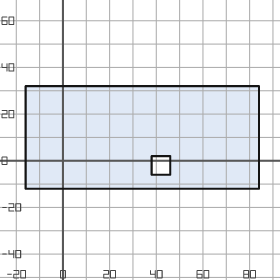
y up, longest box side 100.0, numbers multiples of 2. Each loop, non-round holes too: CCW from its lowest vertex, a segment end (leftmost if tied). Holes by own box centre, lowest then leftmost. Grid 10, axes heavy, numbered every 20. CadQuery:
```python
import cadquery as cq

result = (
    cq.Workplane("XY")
    .moveTo(-16.0, -12.0)
    .lineTo(84.0, -12.0)
    .lineTo(84.0, 32.0)
    .lineTo(-16.0, 32.0)
    .close()
    .moveTo(38.0, -6.0)
    .lineTo(46.0, -6.0)
    .lineTo(46.0, 2.0)
    .lineTo(38.0, 2.0)
    .close()
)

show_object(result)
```